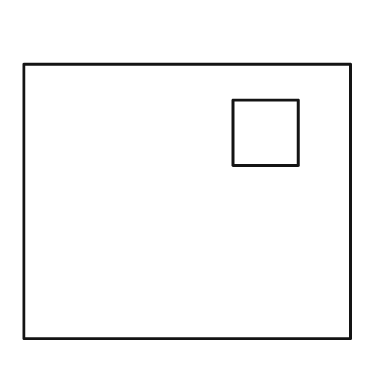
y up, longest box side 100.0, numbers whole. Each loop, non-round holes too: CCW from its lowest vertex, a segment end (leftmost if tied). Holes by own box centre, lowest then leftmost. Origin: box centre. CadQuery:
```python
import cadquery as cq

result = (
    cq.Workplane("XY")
    .moveTo(-50.0, -42.0)
    .lineTo(50.0, -42.0)
    .lineTo(50.0, 42.0)
    .lineTo(-50.0, 42.0)
    .close()
    .moveTo(14.0, 11.0)
    .lineTo(34.0, 11.0)
    .lineTo(34.0, 31.0)
    .lineTo(14.0, 31.0)
    .close()
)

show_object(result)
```